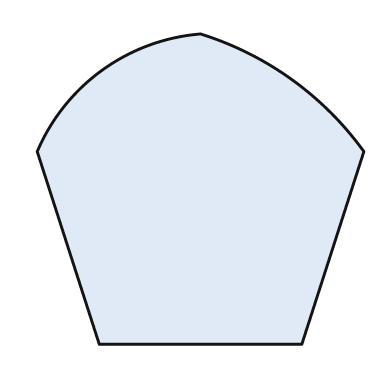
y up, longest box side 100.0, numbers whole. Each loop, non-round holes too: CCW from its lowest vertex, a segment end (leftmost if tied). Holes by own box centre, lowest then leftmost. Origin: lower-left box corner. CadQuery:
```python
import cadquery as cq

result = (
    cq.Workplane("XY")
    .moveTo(19.0, 0.0)
    .lineTo(81.0, 0.0)
    .lineTo(100.0, 59.0)
    .threePointArc((78.0, 81.0), (50.0, 95.0))
    .threePointArc((20.0, 84.0), (0.0, 59.0))
    .close()
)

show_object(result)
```